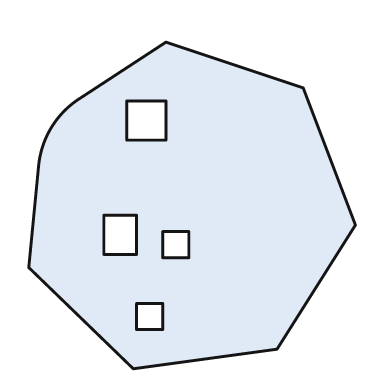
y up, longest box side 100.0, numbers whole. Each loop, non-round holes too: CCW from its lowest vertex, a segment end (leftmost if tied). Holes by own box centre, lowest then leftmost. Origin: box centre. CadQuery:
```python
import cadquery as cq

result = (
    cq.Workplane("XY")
    .moveTo(-18.0, -50.0)
    .lineTo(26.0, -44.0)
    .lineTo(50.0, -6.0)
    .lineTo(34.0, 36.0)
    .lineTo(-8.0, 50.0)
    .lineTo(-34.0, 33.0)
    .threePointArc((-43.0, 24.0), (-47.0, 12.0))
    .lineTo(-50.0, -19.0)
    .close()
    .moveTo(-17.0, -38.0)
    .lineTo(-9.0, -38.0)
    .lineTo(-9.0, -30.0)
    .lineTo(-17.0, -30.0)
    .close()
    .moveTo(-9.0, -16.0)
    .lineTo(-1.0, -16.0)
    .lineTo(-1.0, -8.0)
    .lineTo(-9.0, -8.0)
    .close()
    .moveTo(-27.0, -15.0)
    .lineTo(-17.0, -15.0)
    .lineTo(-17.0, -3.0)
    .lineTo(-27.0, -3.0)
    .close()
    .moveTo(-20.0, 20.0)
    .lineTo(-8.0, 20.0)
    .lineTo(-8.0, 32.0)
    .lineTo(-20.0, 32.0)
    .close()
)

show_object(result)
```